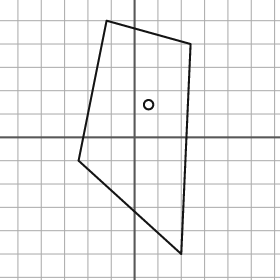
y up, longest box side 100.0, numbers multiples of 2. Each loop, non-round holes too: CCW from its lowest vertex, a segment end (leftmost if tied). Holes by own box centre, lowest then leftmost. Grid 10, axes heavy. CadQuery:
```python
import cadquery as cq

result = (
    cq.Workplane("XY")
    .moveTo(20.0, -50.0)
    .lineTo(24.0, 40.0)
    .lineTo(-12.0, 50.0)
    .lineTo(-24.0, -10.0)
    .close()
    .moveTo(6.0, 14.0)
    .circle(2.0)
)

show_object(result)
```